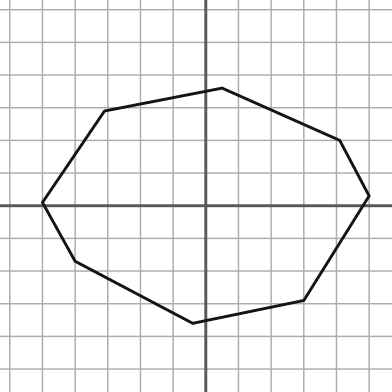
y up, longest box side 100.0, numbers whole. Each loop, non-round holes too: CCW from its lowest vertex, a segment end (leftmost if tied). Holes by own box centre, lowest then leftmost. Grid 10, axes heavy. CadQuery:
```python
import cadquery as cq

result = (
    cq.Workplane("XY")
    .moveTo(-4.0, -36.0)
    .lineTo(30.0, -29.0)
    .lineTo(50.0, 3.0)
    .lineTo(41.0, 20.0)
    .lineTo(5.0, 36.0)
    .lineTo(-31.0, 29.0)
    .lineTo(-50.0, 1.0)
    .lineTo(-40.0, -17.0)
    .close()
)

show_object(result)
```